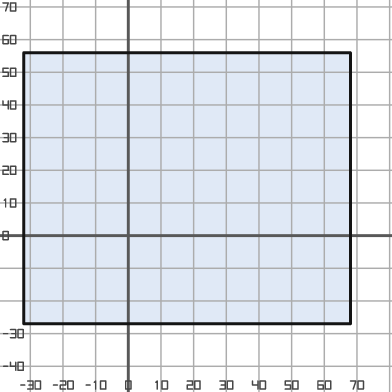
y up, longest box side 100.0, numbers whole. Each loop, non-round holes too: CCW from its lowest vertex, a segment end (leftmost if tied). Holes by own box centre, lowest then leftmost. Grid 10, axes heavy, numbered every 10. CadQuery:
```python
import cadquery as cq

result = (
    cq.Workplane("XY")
    .moveTo(-32.0, -27.0)
    .lineTo(68.0, -27.0)
    .lineTo(68.0, 56.0)
    .lineTo(-32.0, 56.0)
    .close()
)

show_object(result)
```